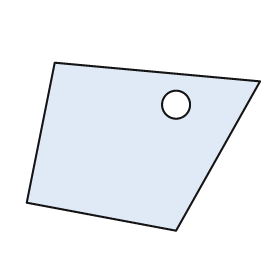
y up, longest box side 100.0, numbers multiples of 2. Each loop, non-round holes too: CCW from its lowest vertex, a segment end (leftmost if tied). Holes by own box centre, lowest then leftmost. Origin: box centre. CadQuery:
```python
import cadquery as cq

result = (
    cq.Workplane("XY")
    .moveTo(14.0, -36.0)
    .lineTo(50.0, 28.0)
    .lineTo(-38.0, 36.0)
    .lineTo(-50.0, -24.0)
    .close()
    .moveTo(14.0, 18.0)
    .circle(6.0)
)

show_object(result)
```